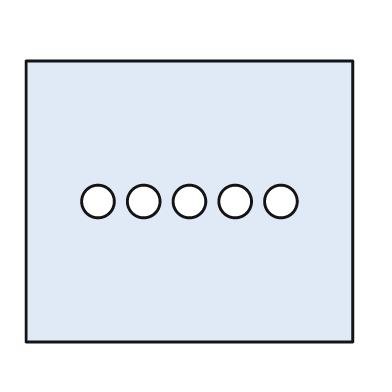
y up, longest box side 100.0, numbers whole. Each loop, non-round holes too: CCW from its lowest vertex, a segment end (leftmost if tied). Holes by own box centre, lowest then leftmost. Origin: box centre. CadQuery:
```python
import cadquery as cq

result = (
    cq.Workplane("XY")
    .moveTo(-50.0, -43.0)
    .lineTo(50.0, -43.0)
    .lineTo(50.0, 43.0)
    .lineTo(-50.0, 43.0)
    .close()
    .moveTo(-28.0, 0.0)
    .circle(5.0)
    .moveTo(-14.0, 0.0)
    .circle(5.0)
    .moveTo(0.0, 0.0)
    .circle(5.0)
    .moveTo(14.0, 0.0)
    .circle(5.0)
    .moveTo(28.0, 0.0)
    .circle(5.0)
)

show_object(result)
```